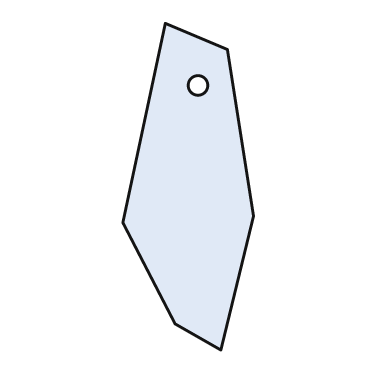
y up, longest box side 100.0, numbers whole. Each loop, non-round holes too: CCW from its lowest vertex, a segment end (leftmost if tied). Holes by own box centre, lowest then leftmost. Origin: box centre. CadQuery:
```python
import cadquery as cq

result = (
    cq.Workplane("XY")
    .moveTo(10.0, -50.0)
    .lineTo(20.0, -9.0)
    .lineTo(12.0, 42.0)
    .lineTo(-7.0, 50.0)
    .lineTo(-20.0, -11.0)
    .lineTo(-4.0, -42.0)
    .close()
    .moveTo(3.0, 31.0)
    .circle(3.0)
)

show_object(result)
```